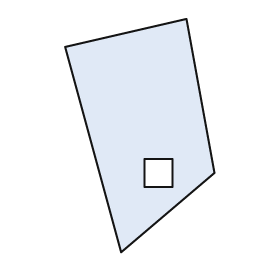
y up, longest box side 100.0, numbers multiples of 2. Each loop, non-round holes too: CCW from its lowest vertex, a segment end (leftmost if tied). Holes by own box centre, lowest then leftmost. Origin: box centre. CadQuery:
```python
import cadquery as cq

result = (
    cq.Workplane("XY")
    .moveTo(-8.0, -50.0)
    .lineTo(32.0, -16.0)
    .lineTo(20.0, 50.0)
    .lineTo(-32.0, 38.0)
    .close()
    .moveTo(2.0, -22.0)
    .lineTo(14.0, -22.0)
    .lineTo(14.0, -10.0)
    .lineTo(2.0, -10.0)
    .close()
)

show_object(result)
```